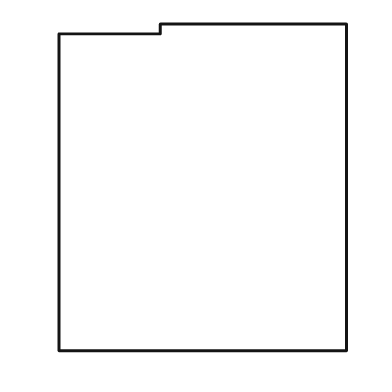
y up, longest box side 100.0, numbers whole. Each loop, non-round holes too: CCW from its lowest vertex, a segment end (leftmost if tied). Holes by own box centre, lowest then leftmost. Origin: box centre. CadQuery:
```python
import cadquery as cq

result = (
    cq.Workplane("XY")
    .moveTo(-44.0, -50.0)
    .lineTo(44.0, -50.0)
    .lineTo(44.0, 50.0)
    .lineTo(-13.0, 50.0)
    .lineTo(-13.0, 47.0)
    .lineTo(-44.0, 47.0)
    .close()
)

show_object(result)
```